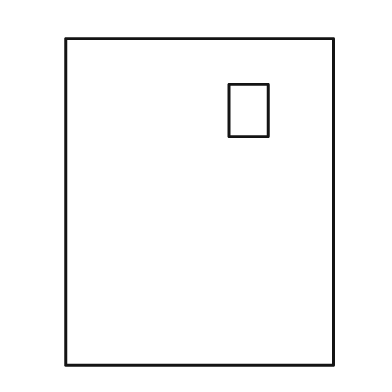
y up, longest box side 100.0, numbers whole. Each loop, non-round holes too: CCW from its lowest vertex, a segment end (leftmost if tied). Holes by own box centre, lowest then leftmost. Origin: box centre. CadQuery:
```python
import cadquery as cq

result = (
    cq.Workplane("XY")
    .moveTo(-41.0, -50.0)
    .lineTo(41.0, -50.0)
    .lineTo(41.0, 50.0)
    .lineTo(-41.0, 50.0)
    .close()
    .moveTo(9.0, 20.0)
    .lineTo(21.0, 20.0)
    .lineTo(21.0, 36.0)
    .lineTo(9.0, 36.0)
    .close()
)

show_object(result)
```